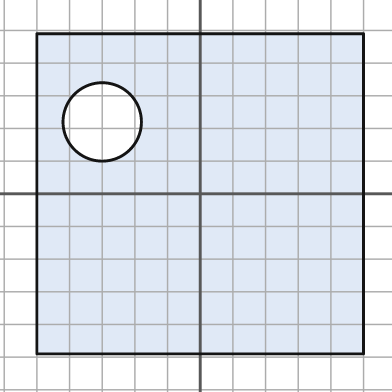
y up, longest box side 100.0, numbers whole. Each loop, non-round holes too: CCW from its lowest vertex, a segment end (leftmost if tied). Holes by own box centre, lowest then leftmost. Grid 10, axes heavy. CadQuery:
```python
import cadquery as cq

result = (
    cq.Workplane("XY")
    .moveTo(-50.0, -49.0)
    .lineTo(50.0, -49.0)
    .lineTo(50.0, 49.0)
    .lineTo(-50.0, 49.0)
    .close()
    .moveTo(-30.0, 22.0)
    .circle(12.0)
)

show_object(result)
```